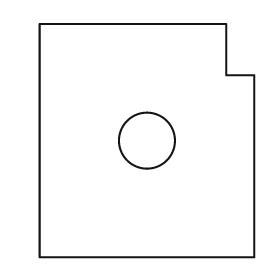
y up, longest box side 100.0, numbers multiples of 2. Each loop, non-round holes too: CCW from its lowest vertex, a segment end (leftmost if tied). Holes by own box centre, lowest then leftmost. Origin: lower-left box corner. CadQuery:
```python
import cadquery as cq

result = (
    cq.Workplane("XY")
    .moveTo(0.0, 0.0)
    .lineTo(92.0, 0.0)
    .lineTo(92.0, 78.0)
    .lineTo(80.0, 78.0)
    .lineTo(80.0, 100.0)
    .lineTo(0.0, 100.0)
    .close()
    .moveTo(46.0, 50.0)
    .circle(12.0)
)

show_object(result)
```